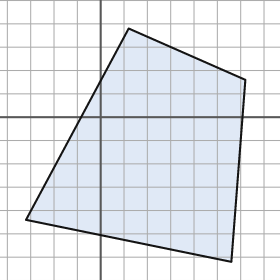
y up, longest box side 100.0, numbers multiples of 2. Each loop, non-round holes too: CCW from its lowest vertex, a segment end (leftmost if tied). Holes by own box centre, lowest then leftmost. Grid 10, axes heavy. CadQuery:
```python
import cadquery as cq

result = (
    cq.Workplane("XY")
    .moveTo(56.0, -62.0)
    .lineTo(62.0, 16.0)
    .lineTo(12.0, 38.0)
    .lineTo(-32.0, -44.0)
    .close()
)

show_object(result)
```